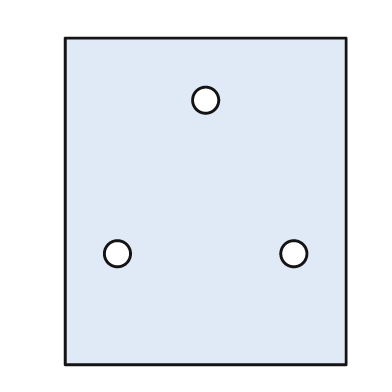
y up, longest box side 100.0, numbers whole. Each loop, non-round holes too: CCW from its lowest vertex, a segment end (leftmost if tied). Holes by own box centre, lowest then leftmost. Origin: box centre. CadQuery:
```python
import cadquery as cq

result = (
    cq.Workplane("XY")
    .moveTo(-43.0, -50.0)
    .lineTo(43.0, -50.0)
    .lineTo(43.0, 50.0)
    .lineTo(-43.0, 50.0)
    .close()
    .moveTo(-27.0, -16.0)
    .circle(4.0)
    .moveTo(27.0, -16.0)
    .circle(4.0)
    .moveTo(0.0, 31.0)
    .circle(4.0)
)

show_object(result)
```